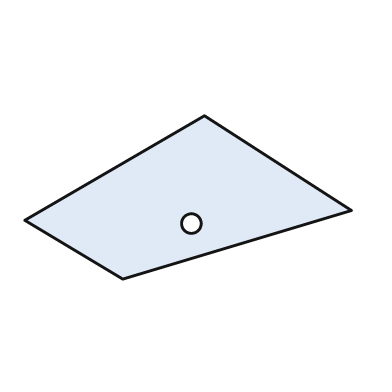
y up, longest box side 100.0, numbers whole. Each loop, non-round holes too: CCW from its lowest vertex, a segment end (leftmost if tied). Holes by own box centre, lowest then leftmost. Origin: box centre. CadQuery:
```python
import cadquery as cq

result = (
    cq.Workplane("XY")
    .moveTo(-20.0, -25.0)
    .lineTo(50.0, -4.0)
    .lineTo(5.0, 25.0)
    .lineTo(-50.0, -7.0)
    .close()
    .moveTo(1.0, -8.0)
    .circle(3.0)
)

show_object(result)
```